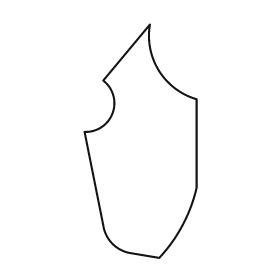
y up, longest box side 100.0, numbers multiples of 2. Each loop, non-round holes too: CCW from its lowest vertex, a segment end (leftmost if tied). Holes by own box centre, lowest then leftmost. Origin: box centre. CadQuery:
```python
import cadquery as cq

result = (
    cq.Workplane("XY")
    .moveTo(8.0, -50.0)
    .threePointArc((18.0, -36.0), (24.0, -20.0))
    .lineTo(24.0, 18.0)
    .threePointArc((8.0, 30.0), (4.0, 50.0))
    .lineTo(-16.0, 26.0)
    .threePointArc((-12.0, 12.0), (-24.0, 4.0))
    .lineTo(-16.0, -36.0)
    .threePointArc((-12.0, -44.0), (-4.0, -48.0))
    .close()
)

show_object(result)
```